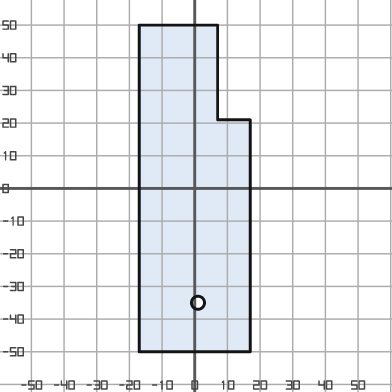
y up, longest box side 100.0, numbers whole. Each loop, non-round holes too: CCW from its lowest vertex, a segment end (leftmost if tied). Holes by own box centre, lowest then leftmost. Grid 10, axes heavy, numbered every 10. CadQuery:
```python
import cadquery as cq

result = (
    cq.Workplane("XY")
    .moveTo(-17.0, -50.0)
    .lineTo(17.0, -50.0)
    .lineTo(17.0, 21.0)
    .lineTo(7.0, 21.0)
    .lineTo(7.0, 50.0)
    .lineTo(-17.0, 50.0)
    .close()
    .moveTo(1.0, -35.0)
    .circle(2.0)
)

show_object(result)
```